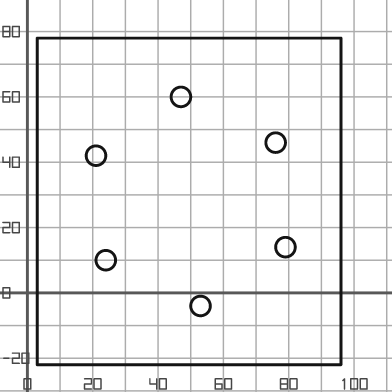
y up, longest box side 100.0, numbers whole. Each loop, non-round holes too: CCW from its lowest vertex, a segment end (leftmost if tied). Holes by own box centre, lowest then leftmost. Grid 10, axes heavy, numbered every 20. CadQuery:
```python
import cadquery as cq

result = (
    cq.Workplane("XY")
    .moveTo(3.0, -22.0)
    .lineTo(96.0, -22.0)
    .lineTo(96.0, 78.0)
    .lineTo(3.0, 78.0)
    .close()
    .moveTo(53.0, -4.0)
    .circle(3.0)
    .moveTo(24.0, 10.0)
    .circle(3.0)
    .moveTo(79.0, 14.0)
    .circle(3.0)
    .moveTo(21.0, 42.0)
    .circle(3.0)
    .moveTo(76.0, 46.0)
    .circle(3.0)
    .moveTo(47.0, 60.0)
    .circle(3.0)
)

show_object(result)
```